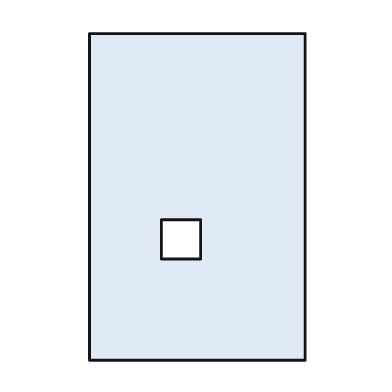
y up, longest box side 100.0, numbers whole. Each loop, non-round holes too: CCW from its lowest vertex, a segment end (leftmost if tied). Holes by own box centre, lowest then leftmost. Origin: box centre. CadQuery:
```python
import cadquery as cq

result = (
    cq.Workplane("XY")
    .moveTo(-33.0, -50.0)
    .lineTo(33.0, -50.0)
    .lineTo(33.0, 50.0)
    .lineTo(-33.0, 50.0)
    .close()
    .moveTo(-11.0, -19.0)
    .lineTo(1.0, -19.0)
    .lineTo(1.0, -7.0)
    .lineTo(-11.0, -7.0)
    .close()
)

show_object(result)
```